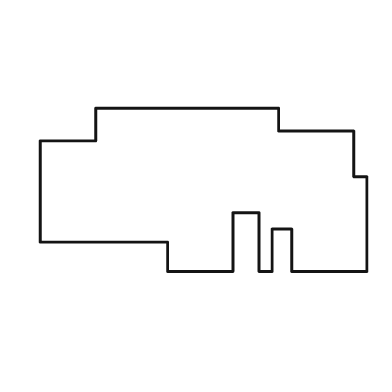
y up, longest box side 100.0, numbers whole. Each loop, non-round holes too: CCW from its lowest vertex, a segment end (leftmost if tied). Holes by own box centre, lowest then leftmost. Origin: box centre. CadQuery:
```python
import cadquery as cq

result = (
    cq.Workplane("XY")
    .moveTo(-11.0, -25.0)
    .lineTo(9.0, -25.0)
    .lineTo(9.0, -7.0)
    .lineTo(17.0, -7.0)
    .lineTo(17.0, -25.0)
    .lineTo(21.0, -25.0)
    .lineTo(21.0, -12.0)
    .lineTo(27.0, -12.0)
    .lineTo(27.0, -25.0)
    .lineTo(50.0, -25.0)
    .lineTo(50.0, 4.0)
    .lineTo(46.0, 4.0)
    .lineTo(46.0, 18.0)
    .lineTo(23.0, 18.0)
    .lineTo(23.0, 25.0)
    .lineTo(-33.0, 25.0)
    .lineTo(-33.0, 15.0)
    .lineTo(-50.0, 15.0)
    .lineTo(-50.0, -16.0)
    .lineTo(-11.0, -16.0)
    .close()
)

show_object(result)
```